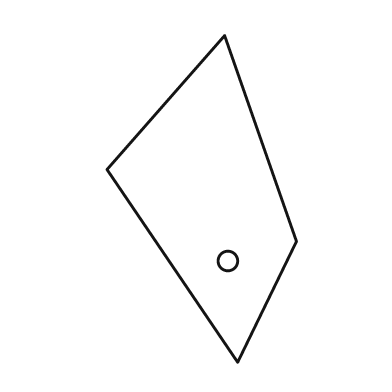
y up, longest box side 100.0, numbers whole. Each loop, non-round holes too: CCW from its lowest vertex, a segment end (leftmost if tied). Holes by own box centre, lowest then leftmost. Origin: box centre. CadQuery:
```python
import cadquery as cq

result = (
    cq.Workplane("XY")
    .moveTo(11.0, -50.0)
    .lineTo(29.0, -13.0)
    .lineTo(7.0, 50.0)
    .lineTo(-29.0, 9.0)
    .close()
    .moveTo(8.0, -19.0)
    .circle(3.0)
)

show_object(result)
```